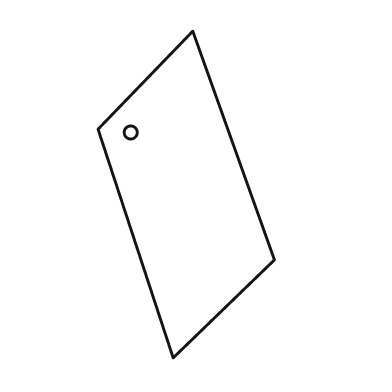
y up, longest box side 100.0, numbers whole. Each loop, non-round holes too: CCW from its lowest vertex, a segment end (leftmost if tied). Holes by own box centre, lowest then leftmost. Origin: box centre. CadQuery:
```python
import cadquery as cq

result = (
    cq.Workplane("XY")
    .moveTo(-4.0, -50.0)
    .lineTo(27.0, -20.0)
    .lineTo(2.0, 50.0)
    .lineTo(-27.0, 20.0)
    .close()
    .moveTo(-17.0, 19.0)
    .circle(2.0)
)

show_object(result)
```